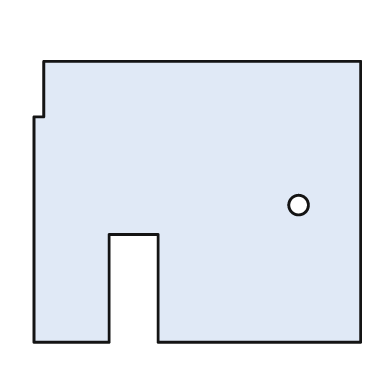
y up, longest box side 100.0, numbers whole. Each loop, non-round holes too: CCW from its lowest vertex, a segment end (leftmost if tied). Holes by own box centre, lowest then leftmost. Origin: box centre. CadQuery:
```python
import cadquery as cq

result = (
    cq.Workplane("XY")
    .moveTo(-50.0, -43.0)
    .lineTo(-27.0, -43.0)
    .lineTo(-27.0, -10.0)
    .lineTo(-12.0, -10.0)
    .lineTo(-12.0, -43.0)
    .lineTo(50.0, -43.0)
    .lineTo(50.0, 43.0)
    .lineTo(-47.0, 43.0)
    .lineTo(-47.0, 26.0)
    .lineTo(-50.0, 26.0)
    .close()
    .moveTo(31.0, -1.0)
    .circle(3.0)
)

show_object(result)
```